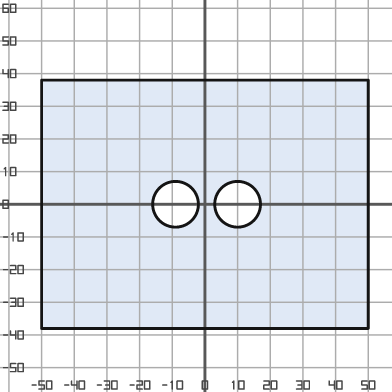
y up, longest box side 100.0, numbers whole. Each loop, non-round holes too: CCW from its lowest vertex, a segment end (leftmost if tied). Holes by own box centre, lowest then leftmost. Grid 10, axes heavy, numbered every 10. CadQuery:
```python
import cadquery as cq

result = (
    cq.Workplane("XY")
    .moveTo(-50.0, -38.0)
    .lineTo(50.0, -38.0)
    .lineTo(50.0, 38.0)
    .lineTo(-50.0, 38.0)
    .close()
    .moveTo(-9.0, 0.0)
    .circle(7.0)
    .moveTo(10.0, 0.0)
    .circle(7.0)
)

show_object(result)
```